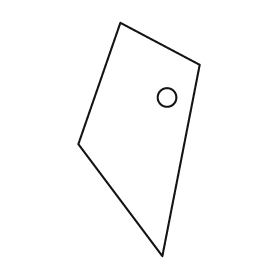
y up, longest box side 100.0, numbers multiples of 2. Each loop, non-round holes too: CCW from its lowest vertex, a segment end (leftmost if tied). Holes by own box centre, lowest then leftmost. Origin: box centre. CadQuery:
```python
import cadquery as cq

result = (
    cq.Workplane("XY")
    .moveTo(10.0, -50.0)
    .lineTo(26.0, 32.0)
    .lineTo(-8.0, 50.0)
    .lineTo(-26.0, -2.0)
    .close()
    .moveTo(12.0, 18.0)
    .circle(4.0)
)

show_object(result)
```